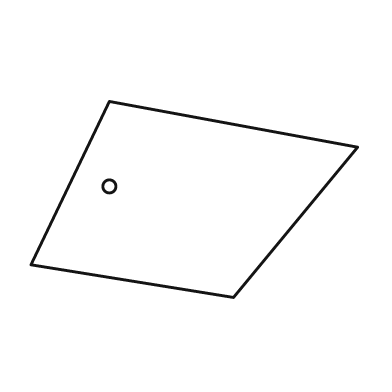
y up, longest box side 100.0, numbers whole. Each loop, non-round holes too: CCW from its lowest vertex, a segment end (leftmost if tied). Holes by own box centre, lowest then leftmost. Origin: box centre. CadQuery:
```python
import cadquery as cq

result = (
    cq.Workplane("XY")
    .moveTo(12.0, -30.0)
    .lineTo(50.0, 16.0)
    .lineTo(-26.0, 30.0)
    .lineTo(-50.0, -20.0)
    .close()
    .moveTo(-26.0, 4.0)
    .circle(2.0)
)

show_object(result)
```